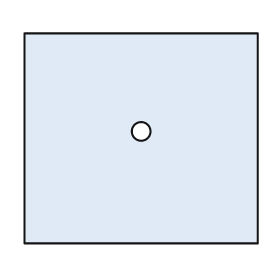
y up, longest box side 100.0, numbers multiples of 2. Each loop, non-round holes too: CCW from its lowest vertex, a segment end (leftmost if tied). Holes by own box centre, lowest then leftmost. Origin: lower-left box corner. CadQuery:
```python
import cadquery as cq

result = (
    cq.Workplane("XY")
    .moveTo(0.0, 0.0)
    .lineTo(100.0, 0.0)
    .lineTo(100.0, 90.0)
    .lineTo(0.0, 90.0)
    .close()
    .moveTo(50.0, 48.0)
    .circle(4.0)
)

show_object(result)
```